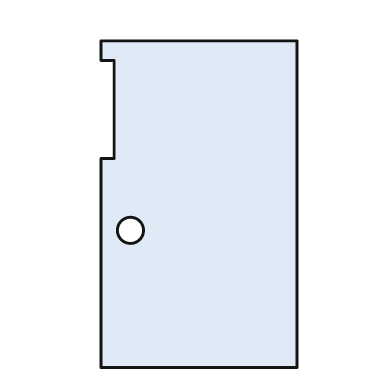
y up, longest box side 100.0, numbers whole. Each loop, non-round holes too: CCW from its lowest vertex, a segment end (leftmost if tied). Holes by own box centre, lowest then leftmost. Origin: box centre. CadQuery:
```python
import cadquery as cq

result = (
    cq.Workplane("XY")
    .moveTo(-30.0, -50.0)
    .lineTo(30.0, -50.0)
    .lineTo(30.0, 50.0)
    .lineTo(-30.0, 50.0)
    .lineTo(-30.0, 44.0)
    .lineTo(-26.0, 44.0)
    .lineTo(-26.0, 14.0)
    .lineTo(-30.0, 14.0)
    .close()
    .moveTo(-21.0, -8.0)
    .circle(4.0)
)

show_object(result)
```